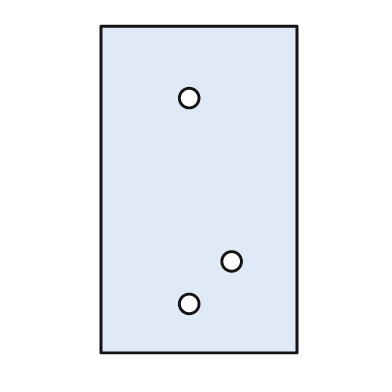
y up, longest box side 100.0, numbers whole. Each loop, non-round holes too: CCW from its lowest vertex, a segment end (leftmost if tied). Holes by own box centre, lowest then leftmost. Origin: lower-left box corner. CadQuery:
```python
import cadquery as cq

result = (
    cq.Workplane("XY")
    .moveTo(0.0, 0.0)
    .lineTo(60.0, 0.0)
    .lineTo(60.0, 100.0)
    .lineTo(0.0, 100.0)
    .close()
    .moveTo(27.0, 15.0)
    .circle(3.0)
    .moveTo(40.0, 28.0)
    .circle(3.0)
    .moveTo(27.0, 78.0)
    .circle(3.0)
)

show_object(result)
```